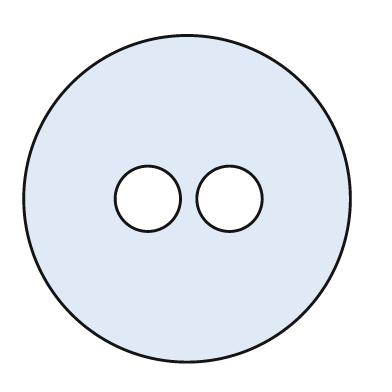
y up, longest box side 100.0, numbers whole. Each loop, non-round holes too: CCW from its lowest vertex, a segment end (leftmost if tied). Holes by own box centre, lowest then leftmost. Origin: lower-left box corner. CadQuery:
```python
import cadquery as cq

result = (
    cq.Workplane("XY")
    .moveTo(50.0, 50.0)
    .circle(50.0)
    .moveTo(38.0, 50.0)
    .circle(10.0)
    .moveTo(63.0, 50.0)
    .circle(10.0)
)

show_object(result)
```